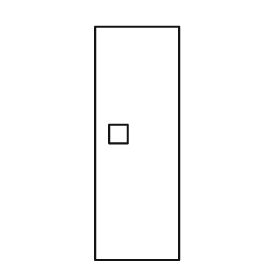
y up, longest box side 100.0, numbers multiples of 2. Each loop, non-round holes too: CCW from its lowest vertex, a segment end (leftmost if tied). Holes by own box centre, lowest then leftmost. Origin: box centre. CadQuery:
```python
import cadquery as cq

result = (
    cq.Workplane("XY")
    .moveTo(-18.0, -50.0)
    .lineTo(18.0, -50.0)
    .lineTo(18.0, 50.0)
    .lineTo(-18.0, 50.0)
    .close()
    .moveTo(-12.0, 0.0)
    .lineTo(-4.0, 0.0)
    .lineTo(-4.0, 8.0)
    .lineTo(-12.0, 8.0)
    .close()
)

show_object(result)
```